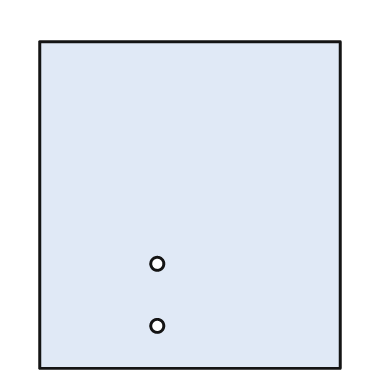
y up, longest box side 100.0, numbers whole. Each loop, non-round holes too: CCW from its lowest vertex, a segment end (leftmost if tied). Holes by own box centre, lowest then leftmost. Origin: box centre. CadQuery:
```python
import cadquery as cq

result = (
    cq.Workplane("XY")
    .moveTo(-46.0, -50.0)
    .lineTo(46.0, -50.0)
    .lineTo(46.0, 50.0)
    .lineTo(-46.0, 50.0)
    .close()
    .moveTo(-10.0, -37.0)
    .circle(2.0)
    .moveTo(-10.0, -18.0)
    .circle(2.0)
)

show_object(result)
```